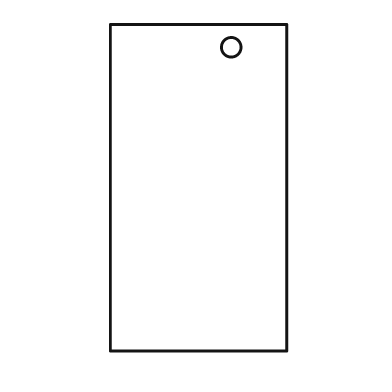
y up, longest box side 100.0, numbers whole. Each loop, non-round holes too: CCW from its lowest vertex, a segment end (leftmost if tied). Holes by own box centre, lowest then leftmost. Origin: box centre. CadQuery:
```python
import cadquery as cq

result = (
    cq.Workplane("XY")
    .moveTo(-27.0, -50.0)
    .lineTo(27.0, -50.0)
    .lineTo(27.0, 50.0)
    .lineTo(-27.0, 50.0)
    .close()
    .moveTo(10.0, 43.0)
    .circle(3.0)
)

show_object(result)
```